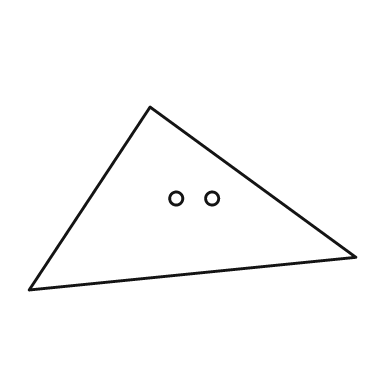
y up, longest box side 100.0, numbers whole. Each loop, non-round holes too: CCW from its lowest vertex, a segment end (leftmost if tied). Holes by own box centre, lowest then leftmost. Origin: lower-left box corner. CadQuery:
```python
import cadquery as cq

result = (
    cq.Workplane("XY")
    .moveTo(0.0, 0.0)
    .lineTo(100.0, 10.0)
    .lineTo(37.0, 56.0)
    .close()
    .moveTo(45.0, 28.0)
    .circle(2.0)
    .moveTo(56.0, 28.0)
    .circle(2.0)
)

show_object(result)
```